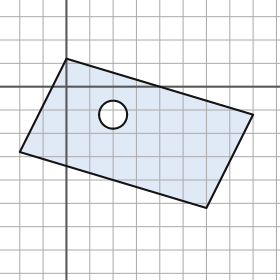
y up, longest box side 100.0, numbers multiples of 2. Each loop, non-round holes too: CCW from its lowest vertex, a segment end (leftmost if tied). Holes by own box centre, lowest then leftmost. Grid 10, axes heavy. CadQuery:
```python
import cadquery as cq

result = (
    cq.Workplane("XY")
    .moveTo(60.0, -52.0)
    .lineTo(80.0, -12.0)
    .lineTo(0.0, 12.0)
    .lineTo(-20.0, -28.0)
    .close()
    .moveTo(20.0, -12.0)
    .circle(6.0)
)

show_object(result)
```